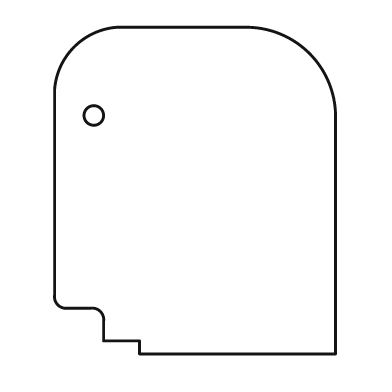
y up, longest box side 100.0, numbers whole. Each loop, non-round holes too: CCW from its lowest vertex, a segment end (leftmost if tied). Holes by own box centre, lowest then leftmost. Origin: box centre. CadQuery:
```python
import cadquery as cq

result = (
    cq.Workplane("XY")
    .moveTo(-17.0, -50.0)
    .lineTo(43.0, -50.0)
    .lineTo(43.0, 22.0)
    .threePointArc((35.0, 42.0), (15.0, 50.0))
    .lineTo(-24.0, 50.0)
    .threePointArc((-37.0, 44.0), (-43.0, 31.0))
    .lineTo(-43.0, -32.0)
    .threePointArc((-42.0, -35.0), (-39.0, -36.0))
    .lineTo(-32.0, -36.0)
    .threePointArc((-29.0, -37.0), (-28.0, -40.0))
    .lineTo(-28.0, -46.0)
    .lineTo(-17.0, -46.0)
    .close()
    .moveTo(-31.0, 23.0)
    .circle(3.0)
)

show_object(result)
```